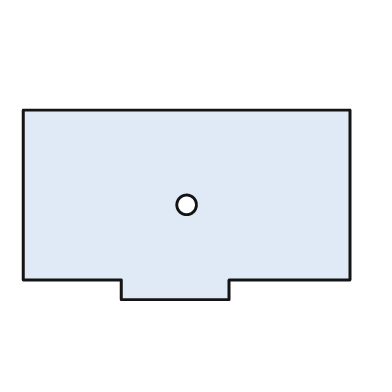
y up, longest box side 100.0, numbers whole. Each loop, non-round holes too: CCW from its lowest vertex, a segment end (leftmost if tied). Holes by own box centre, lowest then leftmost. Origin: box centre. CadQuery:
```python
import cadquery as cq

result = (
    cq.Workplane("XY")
    .moveTo(-20.0, -29.0)
    .lineTo(13.0, -29.0)
    .lineTo(13.0, -23.0)
    .lineTo(50.0, -23.0)
    .lineTo(50.0, 29.0)
    .lineTo(-50.0, 29.0)
    .lineTo(-50.0, -23.0)
    .lineTo(-20.0, -23.0)
    .close()
    .moveTo(0.0, 0.0)
    .circle(3.0)
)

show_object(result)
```